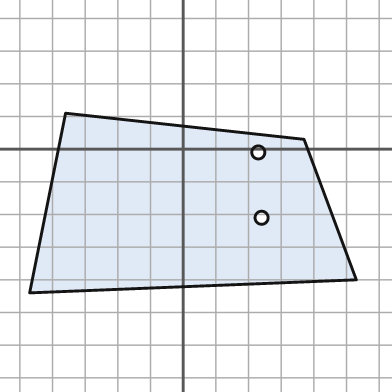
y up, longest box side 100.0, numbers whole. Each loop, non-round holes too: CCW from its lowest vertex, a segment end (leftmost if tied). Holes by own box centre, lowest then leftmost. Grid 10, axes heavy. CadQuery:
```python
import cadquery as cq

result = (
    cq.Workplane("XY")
    .moveTo(-47.0, -44.0)
    .lineTo(53.0, -40.0)
    .lineTo(37.0, 3.0)
    .lineTo(-36.0, 11.0)
    .close()
    .moveTo(24.0, -21.0)
    .circle(2.0)
    .moveTo(23.0, -1.0)
    .circle(2.0)
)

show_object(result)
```